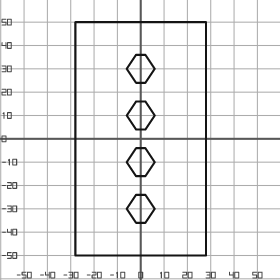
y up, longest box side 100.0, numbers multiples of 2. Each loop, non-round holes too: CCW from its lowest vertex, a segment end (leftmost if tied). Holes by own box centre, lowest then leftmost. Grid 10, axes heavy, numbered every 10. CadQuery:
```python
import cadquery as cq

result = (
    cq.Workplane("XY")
    .moveTo(-28.0, -50.0)
    .lineTo(28.0, -50.0)
    .lineTo(28.0, 50.0)
    .lineTo(-28.0, 50.0)
    .close()
    .moveTo(-2.0, -36.0)
    .lineTo(2.0, -36.0)
    .lineTo(6.0, -30.0)
    .lineTo(2.0, -24.0)
    .lineTo(-2.0, -24.0)
    .lineTo(-6.0, -30.0)
    .close()
    .moveTo(-2.0, -16.0)
    .lineTo(2.0, -16.0)
    .lineTo(6.0, -10.0)
    .lineTo(2.0, -4.0)
    .lineTo(-2.0, -4.0)
    .lineTo(-6.0, -10.0)
    .close()
    .moveTo(-2.0, 4.0)
    .lineTo(2.0, 4.0)
    .lineTo(6.0, 10.0)
    .lineTo(2.0, 16.0)
    .lineTo(-2.0, 16.0)
    .lineTo(-6.0, 10.0)
    .close()
    .moveTo(-2.0, 24.0)
    .lineTo(2.0, 24.0)
    .lineTo(6.0, 30.0)
    .lineTo(2.0, 36.0)
    .lineTo(-2.0, 36.0)
    .lineTo(-6.0, 30.0)
    .close()
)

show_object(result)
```